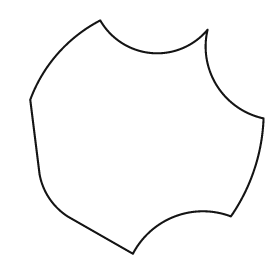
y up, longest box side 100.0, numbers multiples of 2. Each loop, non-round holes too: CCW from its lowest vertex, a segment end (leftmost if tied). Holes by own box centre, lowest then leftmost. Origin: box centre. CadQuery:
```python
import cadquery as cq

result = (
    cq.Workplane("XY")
    .moveTo(-6.0, -50.0)
    .threePointArc((12.0, -34.0), (36.0, -34.0))
    .threePointArc((46.0, -14.0), (50.0, 8.0))
    .threePointArc((30.0, 22.0), (26.0, 46.0))
    .threePointArc((2.0, 36.0), (-20.0, 50.0))
    .threePointArc((-38.0, 36.0), (-50.0, 16.0))
    .lineTo(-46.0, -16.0)
    .threePointArc((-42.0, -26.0), (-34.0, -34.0))
    .close()
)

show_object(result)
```